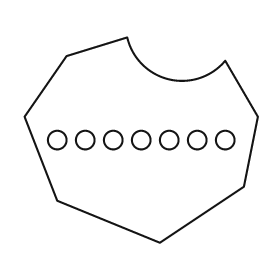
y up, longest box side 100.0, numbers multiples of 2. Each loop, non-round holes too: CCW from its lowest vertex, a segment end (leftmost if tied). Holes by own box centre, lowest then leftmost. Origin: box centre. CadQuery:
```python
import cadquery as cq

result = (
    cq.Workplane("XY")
    .moveTo(8.0, -44.0)
    .lineTo(44.0, -20.0)
    .lineTo(50.0, 10.0)
    .lineTo(36.0, 34.0)
    .threePointArc((12.0, 26.0), (-6.0, 44.0))
    .lineTo(-32.0, 36.0)
    .lineTo(-50.0, 10.0)
    .lineTo(-36.0, -26.0)
    .close()
    .moveTo(-36.0, 0.0)
    .circle(4.0)
    .moveTo(-24.0, 0.0)
    .circle(4.0)
    .moveTo(-12.0, 0.0)
    .circle(4.0)
    .moveTo(0.0, 0.0)
    .circle(4.0)
    .moveTo(12.0, 0.0)
    .circle(4.0)
    .moveTo(24.0, 0.0)
    .circle(4.0)
    .moveTo(36.0, 0.0)
    .circle(4.0)
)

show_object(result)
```